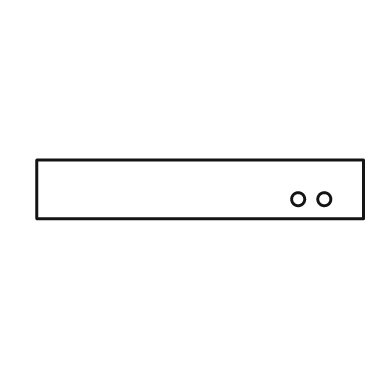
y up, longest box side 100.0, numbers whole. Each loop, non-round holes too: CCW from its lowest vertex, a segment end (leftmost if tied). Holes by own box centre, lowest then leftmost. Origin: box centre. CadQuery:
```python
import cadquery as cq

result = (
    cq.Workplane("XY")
    .moveTo(-50.0, -9.0)
    .lineTo(50.0, -9.0)
    .lineTo(50.0, 9.0)
    .lineTo(-50.0, 9.0)
    .close()
    .moveTo(30.0, -3.0)
    .circle(2.0)
    .moveTo(38.0, -3.0)
    .circle(2.0)
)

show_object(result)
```